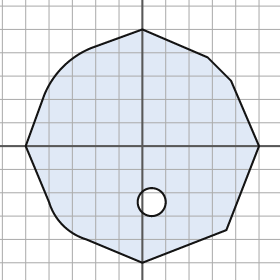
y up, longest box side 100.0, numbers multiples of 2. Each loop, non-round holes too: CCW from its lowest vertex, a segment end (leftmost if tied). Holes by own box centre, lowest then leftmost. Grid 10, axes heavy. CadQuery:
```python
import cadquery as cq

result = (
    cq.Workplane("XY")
    .moveTo(0.0, -50.0)
    .lineTo(36.0, -36.0)
    .lineTo(50.0, 0.0)
    .lineTo(38.0, 28.0)
    .lineTo(28.0, 38.0)
    .lineTo(0.0, 50.0)
    .lineTo(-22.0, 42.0)
    .threePointArc((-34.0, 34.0), (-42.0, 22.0))
    .lineTo(-50.0, 0.0)
    .lineTo(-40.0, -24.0)
    .threePointArc((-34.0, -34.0), (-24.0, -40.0))
    .close()
    .moveTo(4.0, -24.0)
    .circle(6.0)
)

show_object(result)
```